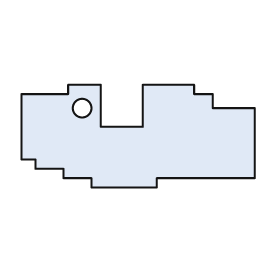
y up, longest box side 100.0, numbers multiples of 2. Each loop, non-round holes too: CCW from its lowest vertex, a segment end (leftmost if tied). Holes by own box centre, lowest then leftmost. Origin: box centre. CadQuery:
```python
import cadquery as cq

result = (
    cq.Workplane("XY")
    .moveTo(-20.0, -22.0)
    .lineTo(8.0, -22.0)
    .lineTo(8.0, -18.0)
    .lineTo(50.0, -18.0)
    .lineTo(50.0, 12.0)
    .lineTo(32.0, 12.0)
    .lineTo(32.0, 18.0)
    .lineTo(24.0, 18.0)
    .lineTo(24.0, 22.0)
    .lineTo(2.0, 22.0)
    .lineTo(2.0, 4.0)
    .lineTo(-16.0, 4.0)
    .lineTo(-16.0, 22.0)
    .lineTo(-30.0, 22.0)
    .lineTo(-30.0, 18.0)
    .lineTo(-50.0, 18.0)
    .lineTo(-50.0, -10.0)
    .lineTo(-44.0, -10.0)
    .lineTo(-44.0, -14.0)
    .lineTo(-32.0, -14.0)
    .lineTo(-32.0, -18.0)
    .lineTo(-20.0, -18.0)
    .close()
    .moveTo(-24.0, 12.0)
    .circle(4.0)
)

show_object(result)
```